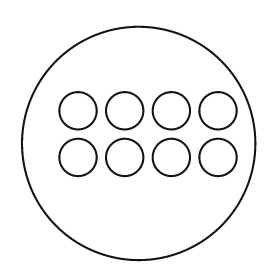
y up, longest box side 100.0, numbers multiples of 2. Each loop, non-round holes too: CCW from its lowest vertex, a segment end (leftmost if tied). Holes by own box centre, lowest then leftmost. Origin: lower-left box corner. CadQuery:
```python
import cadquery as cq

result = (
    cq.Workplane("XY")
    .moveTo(50.0, 50.0)
    .circle(50.0)
    .moveTo(24.0, 44.0)
    .circle(8.0)
    .moveTo(44.0, 44.0)
    .circle(8.0)
    .moveTo(64.0, 44.0)
    .circle(8.0)
    .moveTo(84.0, 44.0)
    .circle(8.0)
    .moveTo(24.0, 64.0)
    .circle(8.0)
    .moveTo(44.0, 64.0)
    .circle(8.0)
    .moveTo(64.0, 64.0)
    .circle(8.0)
    .moveTo(84.0, 64.0)
    .circle(8.0)
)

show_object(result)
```